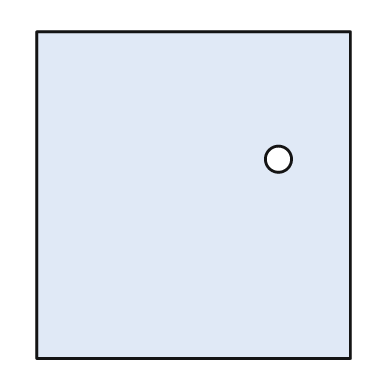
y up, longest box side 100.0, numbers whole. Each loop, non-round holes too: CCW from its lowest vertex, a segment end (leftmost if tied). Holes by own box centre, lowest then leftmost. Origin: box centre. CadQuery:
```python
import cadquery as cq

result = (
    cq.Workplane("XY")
    .moveTo(-48.0, -50.0)
    .lineTo(48.0, -50.0)
    .lineTo(48.0, 50.0)
    .lineTo(-48.0, 50.0)
    .close()
    .moveTo(26.0, 11.0)
    .circle(4.0)
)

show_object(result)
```